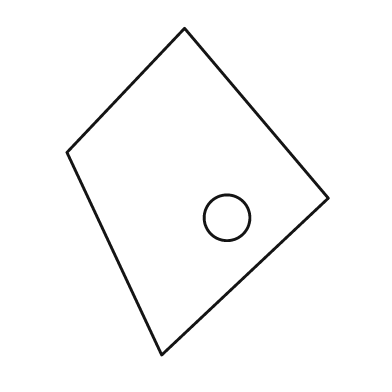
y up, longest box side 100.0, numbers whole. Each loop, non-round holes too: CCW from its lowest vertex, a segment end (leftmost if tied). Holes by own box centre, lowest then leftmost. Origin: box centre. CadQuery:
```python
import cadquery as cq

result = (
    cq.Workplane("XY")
    .moveTo(-11.0, -50.0)
    .lineTo(40.0, -2.0)
    .lineTo(-4.0, 50.0)
    .lineTo(-40.0, 12.0)
    .close()
    .moveTo(9.0, -8.0)
    .circle(7.0)
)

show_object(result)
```